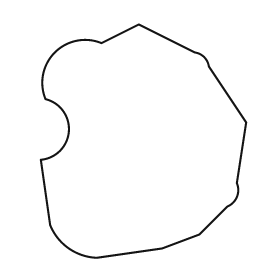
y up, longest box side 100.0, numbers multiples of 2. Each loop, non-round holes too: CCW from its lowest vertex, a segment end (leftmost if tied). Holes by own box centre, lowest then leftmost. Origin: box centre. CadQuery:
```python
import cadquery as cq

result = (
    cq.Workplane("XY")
    .moveTo(-20.0, -50.0)
    .lineTo(8.0, -46.0)
    .lineTo(24.0, -40.0)
    .lineTo(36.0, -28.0)
    .threePointArc((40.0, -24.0), (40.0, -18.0))
    .lineTo(44.0, 8.0)
    .lineTo(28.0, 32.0)
    .threePointArc((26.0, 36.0), (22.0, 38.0))
    .lineTo(-2.0, 50.0)
    .lineTo(-18.0, 42.0)
    .threePointArc((-38.0, 38.0), (-42.0, 18.0))
    .threePointArc((-32.0, 4.0), (-44.0, -8.0))
    .lineTo(-40.0, -36.0)
    .threePointArc((-32.0, -46.0), (-20.0, -50.0))
    .close()
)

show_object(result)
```